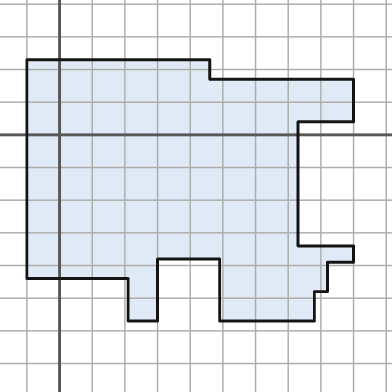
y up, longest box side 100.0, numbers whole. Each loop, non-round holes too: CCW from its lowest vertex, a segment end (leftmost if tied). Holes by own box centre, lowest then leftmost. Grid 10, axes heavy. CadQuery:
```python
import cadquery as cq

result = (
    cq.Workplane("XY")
    .moveTo(21.0, -57.0)
    .lineTo(30.0, -57.0)
    .lineTo(30.0, -38.0)
    .lineTo(49.0, -38.0)
    .lineTo(49.0, -57.0)
    .lineTo(78.0, -57.0)
    .lineTo(78.0, -48.0)
    .lineTo(82.0, -48.0)
    .lineTo(82.0, -39.0)
    .lineTo(90.0, -39.0)
    .lineTo(90.0, -34.0)
    .lineTo(73.0, -34.0)
    .lineTo(73.0, 4.0)
    .lineTo(90.0, 4.0)
    .lineTo(90.0, 17.0)
    .lineTo(46.0, 17.0)
    .lineTo(46.0, 23.0)
    .lineTo(-10.0, 23.0)
    .lineTo(-10.0, -44.0)
    .lineTo(21.0, -44.0)
    .close()
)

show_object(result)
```